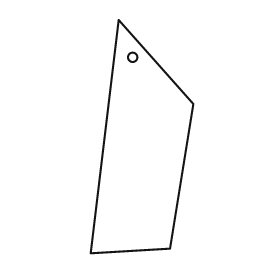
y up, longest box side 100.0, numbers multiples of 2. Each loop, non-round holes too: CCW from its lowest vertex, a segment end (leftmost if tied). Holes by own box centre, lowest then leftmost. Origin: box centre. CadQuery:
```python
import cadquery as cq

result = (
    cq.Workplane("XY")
    .moveTo(-22.0, -50.0)
    .lineTo(12.0, -48.0)
    .lineTo(22.0, 14.0)
    .lineTo(-10.0, 50.0)
    .close()
    .moveTo(-4.0, 34.0)
    .circle(2.0)
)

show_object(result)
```